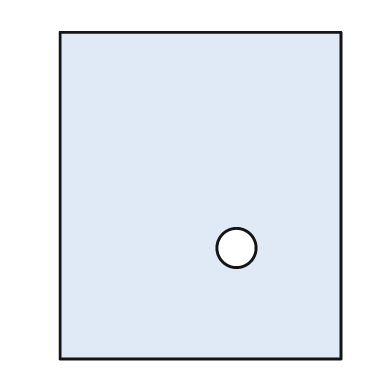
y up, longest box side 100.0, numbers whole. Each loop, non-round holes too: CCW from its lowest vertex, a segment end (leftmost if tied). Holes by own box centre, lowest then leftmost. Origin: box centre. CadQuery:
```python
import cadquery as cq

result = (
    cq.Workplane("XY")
    .moveTo(-43.0, -50.0)
    .lineTo(43.0, -50.0)
    .lineTo(43.0, 50.0)
    .lineTo(-43.0, 50.0)
    .close()
    .moveTo(11.0, -16.0)
    .circle(6.0)
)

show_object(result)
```